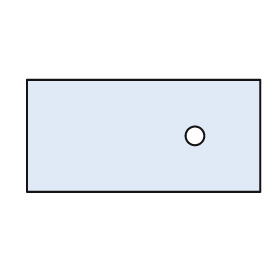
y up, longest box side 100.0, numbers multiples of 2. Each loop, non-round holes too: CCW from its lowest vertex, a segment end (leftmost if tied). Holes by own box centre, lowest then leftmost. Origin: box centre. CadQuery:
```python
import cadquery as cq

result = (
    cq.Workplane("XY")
    .moveTo(-50.0, -24.0)
    .lineTo(50.0, -24.0)
    .lineTo(50.0, 24.0)
    .lineTo(-50.0, 24.0)
    .close()
    .moveTo(22.0, 0.0)
    .circle(4.0)
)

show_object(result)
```